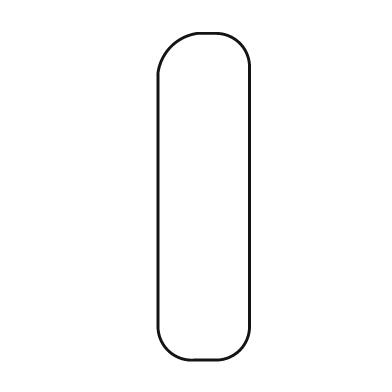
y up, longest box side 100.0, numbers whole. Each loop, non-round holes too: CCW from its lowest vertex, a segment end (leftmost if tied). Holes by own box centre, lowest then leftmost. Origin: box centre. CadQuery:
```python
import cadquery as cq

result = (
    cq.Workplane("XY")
    .moveTo(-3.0, -50.0)
    .lineTo(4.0, -50.0)
    .threePointArc((11.0, -47.0), (14.0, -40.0))
    .lineTo(14.0, 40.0)
    .threePointArc((11.0, 47.0), (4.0, 50.0))
    .lineTo(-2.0, 50.0)
    .threePointArc((-10.0, 46.0), (-14.0, 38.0))
    .lineTo(-14.0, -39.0)
    .threePointArc((-11.0, -47.0), (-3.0, -50.0))
    .close()
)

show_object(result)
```